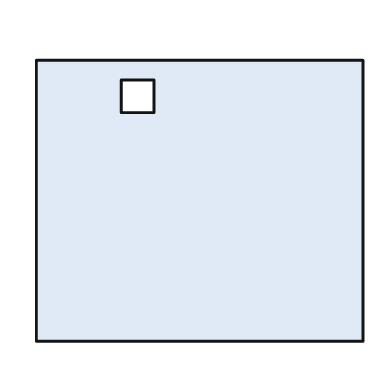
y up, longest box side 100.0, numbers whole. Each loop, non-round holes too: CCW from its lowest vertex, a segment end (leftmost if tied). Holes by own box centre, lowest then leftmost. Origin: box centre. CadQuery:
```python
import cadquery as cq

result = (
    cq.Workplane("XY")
    .moveTo(-50.0, -43.0)
    .lineTo(50.0, -43.0)
    .lineTo(50.0, 43.0)
    .lineTo(-50.0, 43.0)
    .close()
    .moveTo(-24.0, 27.0)
    .lineTo(-14.0, 27.0)
    .lineTo(-14.0, 37.0)
    .lineTo(-24.0, 37.0)
    .close()
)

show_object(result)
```